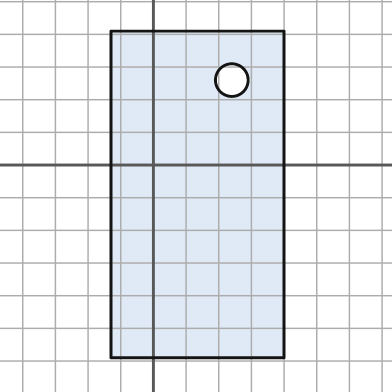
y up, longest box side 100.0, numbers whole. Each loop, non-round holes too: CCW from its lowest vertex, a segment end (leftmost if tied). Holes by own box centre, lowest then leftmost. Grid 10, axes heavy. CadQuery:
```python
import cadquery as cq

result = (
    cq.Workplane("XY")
    .moveTo(-13.0, -59.0)
    .lineTo(40.0, -59.0)
    .lineTo(40.0, 41.0)
    .lineTo(-13.0, 41.0)
    .close()
    .moveTo(24.0, 26.0)
    .circle(5.0)
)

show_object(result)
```